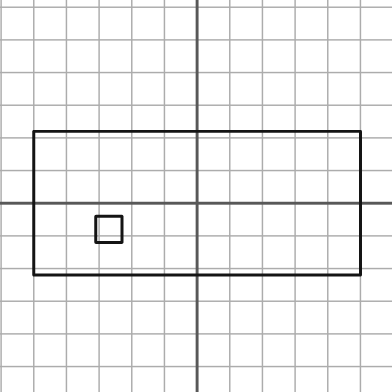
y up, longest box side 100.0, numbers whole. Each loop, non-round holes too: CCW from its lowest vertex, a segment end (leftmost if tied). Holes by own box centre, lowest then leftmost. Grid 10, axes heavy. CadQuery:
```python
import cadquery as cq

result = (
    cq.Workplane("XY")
    .moveTo(-50.0, -22.0)
    .lineTo(50.0, -22.0)
    .lineTo(50.0, 22.0)
    .lineTo(-50.0, 22.0)
    .close()
    .moveTo(-31.0, -12.0)
    .lineTo(-23.0, -12.0)
    .lineTo(-23.0, -4.0)
    .lineTo(-31.0, -4.0)
    .close()
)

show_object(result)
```